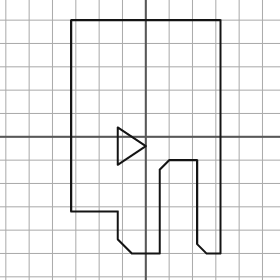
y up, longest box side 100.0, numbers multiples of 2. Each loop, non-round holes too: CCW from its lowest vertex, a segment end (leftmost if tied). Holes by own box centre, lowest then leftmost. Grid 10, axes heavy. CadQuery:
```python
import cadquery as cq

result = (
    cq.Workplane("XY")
    .moveTo(-6.0, -50.0)
    .lineTo(6.0, -50.0)
    .lineTo(6.0, -14.0)
    .lineTo(10.0, -10.0)
    .lineTo(22.0, -10.0)
    .lineTo(22.0, -46.0)
    .lineTo(26.0, -50.0)
    .lineTo(32.0, -50.0)
    .lineTo(32.0, 50.0)
    .lineTo(-32.0, 50.0)
    .lineTo(-32.0, -32.0)
    .lineTo(-12.0, -32.0)
    .lineTo(-12.0, -44.0)
    .close()
    .moveTo(-12.0, -12.0)
    .lineTo(0.0, -4.0)
    .lineTo(-12.0, 4.0)
    .close()
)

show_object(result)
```